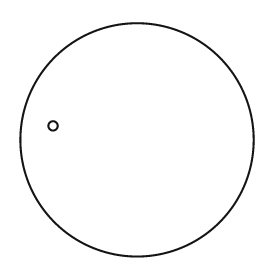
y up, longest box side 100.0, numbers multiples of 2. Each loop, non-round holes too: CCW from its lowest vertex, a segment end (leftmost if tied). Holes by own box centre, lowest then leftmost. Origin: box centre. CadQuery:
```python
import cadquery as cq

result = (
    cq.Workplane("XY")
    .moveTo(0.0, 0.0)
    .circle(50.0)
    .moveTo(-36.0, 6.0)
    .circle(2.0)
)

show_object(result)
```